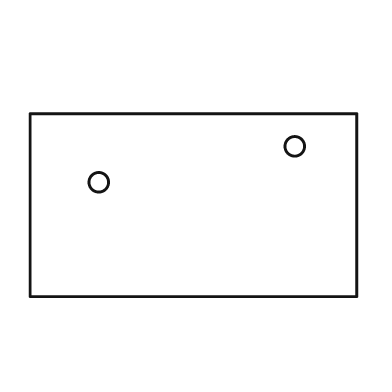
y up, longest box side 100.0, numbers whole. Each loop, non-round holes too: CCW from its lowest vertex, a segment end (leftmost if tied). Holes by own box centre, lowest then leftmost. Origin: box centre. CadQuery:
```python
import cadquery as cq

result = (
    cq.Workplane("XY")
    .moveTo(-50.0, -28.0)
    .lineTo(50.0, -28.0)
    .lineTo(50.0, 28.0)
    .lineTo(-50.0, 28.0)
    .close()
    .moveTo(-29.0, 7.0)
    .circle(3.0)
    .moveTo(31.0, 18.0)
    .circle(3.0)
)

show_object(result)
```